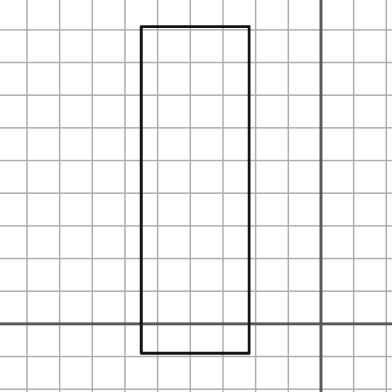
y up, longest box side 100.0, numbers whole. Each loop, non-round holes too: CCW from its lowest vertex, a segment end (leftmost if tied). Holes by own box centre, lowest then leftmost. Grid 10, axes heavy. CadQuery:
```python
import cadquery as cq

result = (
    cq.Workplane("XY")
    .moveTo(-55.0, -9.0)
    .lineTo(-22.0, -9.0)
    .lineTo(-22.0, 91.0)
    .lineTo(-55.0, 91.0)
    .close()
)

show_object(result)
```